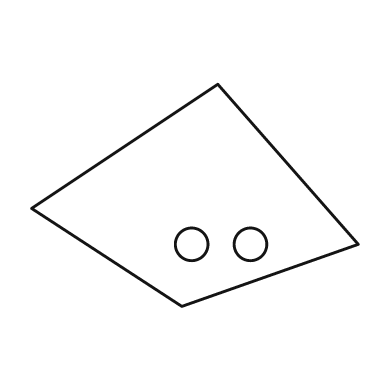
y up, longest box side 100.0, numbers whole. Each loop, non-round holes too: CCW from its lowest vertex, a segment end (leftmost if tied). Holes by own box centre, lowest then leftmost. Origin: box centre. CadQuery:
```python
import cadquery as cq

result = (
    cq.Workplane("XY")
    .moveTo(-4.0, -34.0)
    .lineTo(50.0, -15.0)
    .lineTo(7.0, 34.0)
    .lineTo(-50.0, -4.0)
    .close()
    .moveTo(-1.0, -15.0)
    .circle(5.0)
    .moveTo(17.0, -15.0)
    .circle(5.0)
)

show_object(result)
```